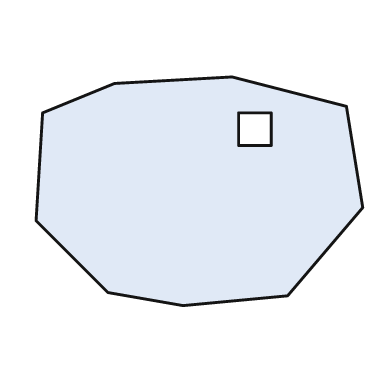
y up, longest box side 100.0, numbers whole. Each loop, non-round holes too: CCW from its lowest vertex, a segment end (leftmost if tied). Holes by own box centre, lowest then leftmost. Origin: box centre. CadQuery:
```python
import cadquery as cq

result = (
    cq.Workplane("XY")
    .moveTo(-5.0, -35.0)
    .lineTo(27.0, -32.0)
    .lineTo(50.0, -5.0)
    .lineTo(45.0, 26.0)
    .lineTo(10.0, 35.0)
    .lineTo(-26.0, 33.0)
    .lineTo(-48.0, 24.0)
    .lineTo(-50.0, -9.0)
    .lineTo(-28.0, -31.0)
    .close()
    .moveTo(12.0, 14.0)
    .lineTo(22.0, 14.0)
    .lineTo(22.0, 24.0)
    .lineTo(12.0, 24.0)
    .close()
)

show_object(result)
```